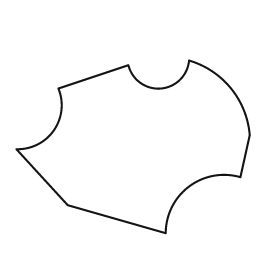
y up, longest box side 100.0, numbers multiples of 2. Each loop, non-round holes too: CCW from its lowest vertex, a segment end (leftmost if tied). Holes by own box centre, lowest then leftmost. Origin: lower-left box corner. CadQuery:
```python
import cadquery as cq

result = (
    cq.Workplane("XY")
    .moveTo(64.0, 0.0)
    .threePointArc((74.0, 20.0), (96.0, 24.0))
    .lineTo(100.0, 42.0)
    .threePointArc((92.0, 62.0), (74.0, 74.0))
    .threePointArc((62.0, 62.0), (48.0, 72.0))
    .lineTo(18.0, 62.0)
    .threePointArc((16.0, 44.0), (0.0, 36.0))
    .lineTo(22.0, 12.0)
    .close()
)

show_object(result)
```